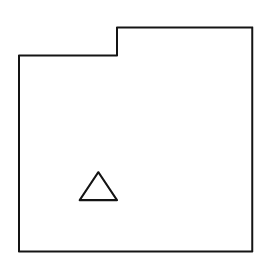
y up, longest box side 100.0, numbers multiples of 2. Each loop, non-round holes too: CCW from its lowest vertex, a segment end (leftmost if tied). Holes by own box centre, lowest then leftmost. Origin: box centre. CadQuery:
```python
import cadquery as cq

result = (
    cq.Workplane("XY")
    .moveTo(-50.0, -48.0)
    .lineTo(50.0, -48.0)
    .lineTo(50.0, 48.0)
    .lineTo(-8.0, 48.0)
    .lineTo(-8.0, 36.0)
    .lineTo(-50.0, 36.0)
    .close()
    .moveTo(-24.0, -26.0)
    .lineTo(-8.0, -26.0)
    .lineTo(-16.0, -14.0)
    .close()
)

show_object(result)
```